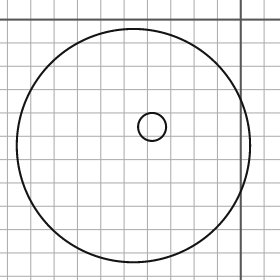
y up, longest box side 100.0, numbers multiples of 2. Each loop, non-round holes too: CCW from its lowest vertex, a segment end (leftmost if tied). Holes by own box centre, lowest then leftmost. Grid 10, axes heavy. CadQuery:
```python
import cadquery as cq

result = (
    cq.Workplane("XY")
    .moveTo(-46.0, -54.0)
    .circle(50.0)
    .moveTo(-38.0, -46.0)
    .circle(6.0)
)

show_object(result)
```